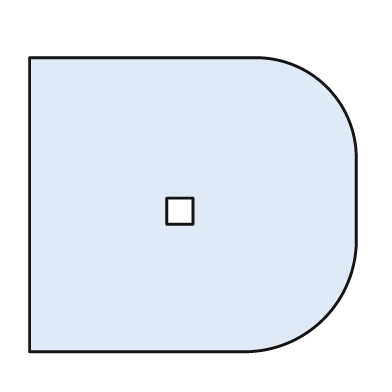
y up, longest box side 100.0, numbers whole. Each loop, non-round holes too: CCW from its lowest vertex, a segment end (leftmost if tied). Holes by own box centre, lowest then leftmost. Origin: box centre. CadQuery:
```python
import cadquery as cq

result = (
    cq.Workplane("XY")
    .moveTo(-50.0, -45.0)
    .lineTo(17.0, -45.0)
    .threePointArc((40.0, -35.0), (50.0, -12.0))
    .lineTo(50.0, 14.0)
    .threePointArc((41.0, 36.0), (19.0, 45.0))
    .lineTo(-50.0, 45.0)
    .close()
    .moveTo(-8.0, -6.0)
    .lineTo(0.0, -6.0)
    .lineTo(0.0, 2.0)
    .lineTo(-8.0, 2.0)
    .close()
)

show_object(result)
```